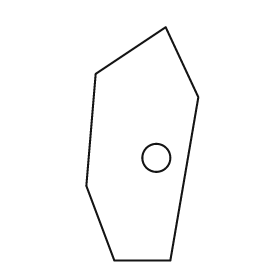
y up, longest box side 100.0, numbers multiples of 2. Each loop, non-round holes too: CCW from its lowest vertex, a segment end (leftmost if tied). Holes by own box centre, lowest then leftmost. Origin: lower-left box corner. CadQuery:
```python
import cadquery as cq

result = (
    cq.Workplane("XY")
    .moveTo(12.0, 0.0)
    .lineTo(36.0, 0.0)
    .lineTo(48.0, 70.0)
    .lineTo(34.0, 100.0)
    .lineTo(4.0, 80.0)
    .lineTo(0.0, 32.0)
    .close()
    .moveTo(30.0, 44.0)
    .circle(6.0)
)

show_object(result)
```